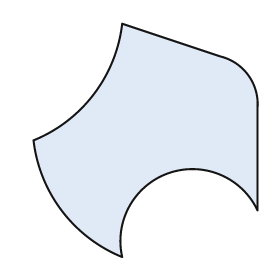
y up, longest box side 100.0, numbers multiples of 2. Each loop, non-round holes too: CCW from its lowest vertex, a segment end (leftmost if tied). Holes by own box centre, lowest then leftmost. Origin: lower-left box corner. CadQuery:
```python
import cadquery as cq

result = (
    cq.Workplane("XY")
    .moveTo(38.0, 0.0)
    .threePointArc((58.0, 36.0), (96.0, 20.0))
    .lineTo(96.0, 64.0)
    .threePointArc((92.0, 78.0), (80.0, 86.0))
    .lineTo(38.0, 100.0)
    .threePointArc((26.0, 70.0), (0.0, 50.0))
    .threePointArc((12.0, 20.0), (38.0, 0.0))
    .close()
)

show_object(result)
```